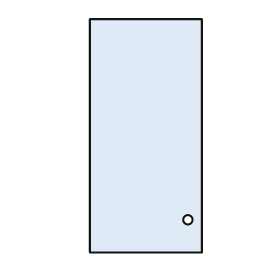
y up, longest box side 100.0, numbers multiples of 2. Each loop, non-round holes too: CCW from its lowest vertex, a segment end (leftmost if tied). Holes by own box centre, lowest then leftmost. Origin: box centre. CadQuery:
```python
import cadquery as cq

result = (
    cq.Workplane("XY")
    .moveTo(-24.0, -50.0)
    .lineTo(24.0, -50.0)
    .lineTo(24.0, 50.0)
    .lineTo(-24.0, 50.0)
    .close()
    .moveTo(18.0, -36.0)
    .circle(2.0)
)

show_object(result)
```